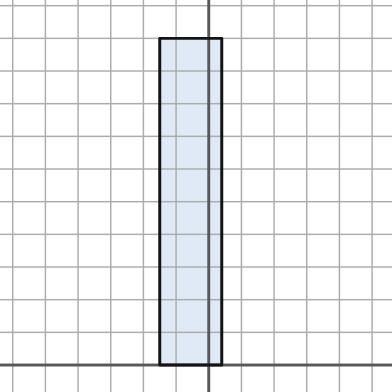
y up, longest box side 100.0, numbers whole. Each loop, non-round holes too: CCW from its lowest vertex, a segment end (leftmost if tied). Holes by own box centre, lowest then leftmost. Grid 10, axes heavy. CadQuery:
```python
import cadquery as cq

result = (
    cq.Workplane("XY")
    .moveTo(-15.0, 0.0)
    .lineTo(4.0, 0.0)
    .lineTo(4.0, 100.0)
    .lineTo(-15.0, 100.0)
    .close()
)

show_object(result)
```